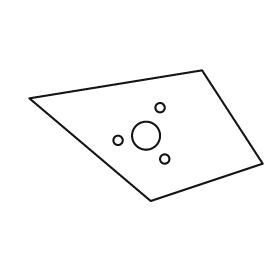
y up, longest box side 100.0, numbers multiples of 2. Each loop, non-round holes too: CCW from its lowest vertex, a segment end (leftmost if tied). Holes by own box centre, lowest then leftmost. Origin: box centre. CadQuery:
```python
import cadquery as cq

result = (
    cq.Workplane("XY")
    .moveTo(2.0, -28.0)
    .lineTo(50.0, -12.0)
    .lineTo(24.0, 28.0)
    .lineTo(-50.0, 16.0)
    .close()
    .moveTo(8.0, -10.0)
    .circle(2.0)
    .moveTo(-12.0, -2.0)
    .circle(2.0)
    .moveTo(0.0, 0.0)
    .circle(6.0)
    .moveTo(6.0, 12.0)
    .circle(2.0)
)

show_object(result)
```